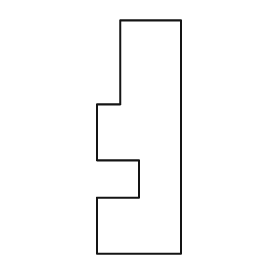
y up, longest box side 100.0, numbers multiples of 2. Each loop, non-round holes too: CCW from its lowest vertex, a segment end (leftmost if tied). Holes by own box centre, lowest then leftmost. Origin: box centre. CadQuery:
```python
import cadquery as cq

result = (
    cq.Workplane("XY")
    .moveTo(-18.0, -50.0)
    .lineTo(18.0, -50.0)
    .lineTo(18.0, 50.0)
    .lineTo(-8.0, 50.0)
    .lineTo(-8.0, 14.0)
    .lineTo(-18.0, 14.0)
    .lineTo(-18.0, -10.0)
    .lineTo(0.0, -10.0)
    .lineTo(0.0, -26.0)
    .lineTo(-18.0, -26.0)
    .close()
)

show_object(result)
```